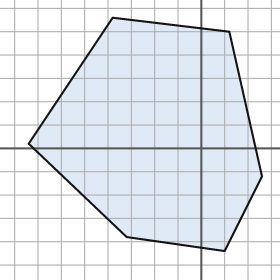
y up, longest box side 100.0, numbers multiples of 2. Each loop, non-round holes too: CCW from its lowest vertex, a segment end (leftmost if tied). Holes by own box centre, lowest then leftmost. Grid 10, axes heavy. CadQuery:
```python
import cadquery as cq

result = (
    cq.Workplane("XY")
    .moveTo(10.0, -44.0)
    .lineTo(26.0, -12.0)
    .lineTo(12.0, 50.0)
    .lineTo(-38.0, 56.0)
    .lineTo(-74.0, 2.0)
    .lineTo(-32.0, -38.0)
    .close()
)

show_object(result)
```